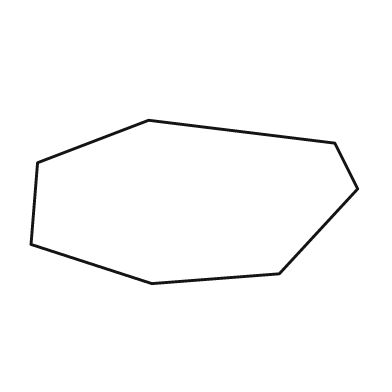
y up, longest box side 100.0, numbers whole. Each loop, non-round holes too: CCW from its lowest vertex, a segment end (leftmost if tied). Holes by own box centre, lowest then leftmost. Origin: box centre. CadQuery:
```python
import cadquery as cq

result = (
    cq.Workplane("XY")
    .moveTo(-13.0, -25.0)
    .lineTo(26.0, -22.0)
    .lineTo(50.0, 4.0)
    .lineTo(43.0, 18.0)
    .lineTo(-14.0, 25.0)
    .lineTo(-48.0, 12.0)
    .lineTo(-50.0, -13.0)
    .close()
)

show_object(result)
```